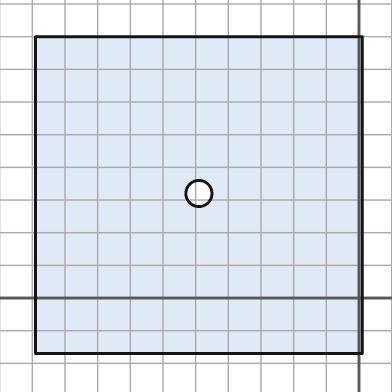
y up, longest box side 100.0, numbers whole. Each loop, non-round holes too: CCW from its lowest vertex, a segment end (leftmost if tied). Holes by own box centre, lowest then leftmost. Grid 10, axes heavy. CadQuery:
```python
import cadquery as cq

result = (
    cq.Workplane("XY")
    .moveTo(-99.0, -17.0)
    .lineTo(1.0, -17.0)
    .lineTo(1.0, 80.0)
    .lineTo(-99.0, 80.0)
    .close()
    .moveTo(-49.0, 32.0)
    .circle(4.0)
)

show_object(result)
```